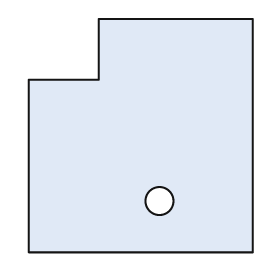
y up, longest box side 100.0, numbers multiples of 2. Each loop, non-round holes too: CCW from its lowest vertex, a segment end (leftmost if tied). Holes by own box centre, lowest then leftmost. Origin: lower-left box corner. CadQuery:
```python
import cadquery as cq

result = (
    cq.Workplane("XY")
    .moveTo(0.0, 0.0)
    .lineTo(96.0, 0.0)
    .lineTo(96.0, 100.0)
    .lineTo(30.0, 100.0)
    .lineTo(30.0, 74.0)
    .lineTo(0.0, 74.0)
    .close()
    .moveTo(56.0, 22.0)
    .circle(6.0)
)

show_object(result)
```